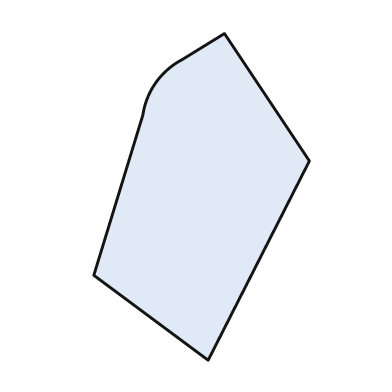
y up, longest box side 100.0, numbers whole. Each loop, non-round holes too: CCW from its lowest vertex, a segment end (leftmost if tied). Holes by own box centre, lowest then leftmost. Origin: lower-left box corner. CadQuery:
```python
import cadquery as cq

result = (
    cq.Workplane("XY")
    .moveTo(35.0, 0.0)
    .lineTo(66.0, 61.0)
    .lineTo(40.0, 100.0)
    .lineTo(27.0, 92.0)
    .threePointArc((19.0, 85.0), (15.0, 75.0))
    .lineTo(0.0, 26.0)
    .close()
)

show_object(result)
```